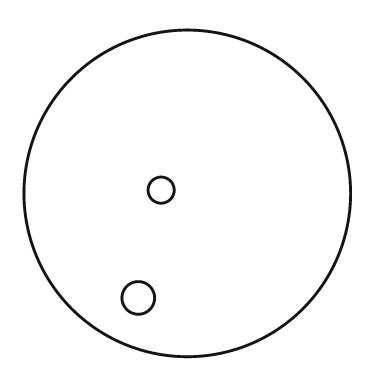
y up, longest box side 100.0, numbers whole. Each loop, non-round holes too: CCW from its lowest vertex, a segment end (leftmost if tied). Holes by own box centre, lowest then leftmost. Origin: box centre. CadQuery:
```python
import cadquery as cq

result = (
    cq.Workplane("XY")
    .moveTo(0.0, 0.0)
    .circle(50.0)
    .moveTo(-15.0, -32.0)
    .circle(5.0)
    .moveTo(-8.0, 1.0)
    .circle(4.0)
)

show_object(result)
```